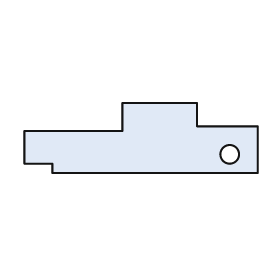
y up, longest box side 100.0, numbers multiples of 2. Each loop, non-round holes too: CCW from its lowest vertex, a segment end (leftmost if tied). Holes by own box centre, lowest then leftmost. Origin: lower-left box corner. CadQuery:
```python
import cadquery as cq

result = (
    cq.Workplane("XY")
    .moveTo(12.0, 0.0)
    .lineTo(100.0, 0.0)
    .lineTo(100.0, 20.0)
    .lineTo(74.0, 20.0)
    .lineTo(74.0, 30.0)
    .lineTo(42.0, 30.0)
    .lineTo(42.0, 18.0)
    .lineTo(0.0, 18.0)
    .lineTo(0.0, 4.0)
    .lineTo(12.0, 4.0)
    .close()
    .moveTo(88.0, 8.0)
    .circle(4.0)
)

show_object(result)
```